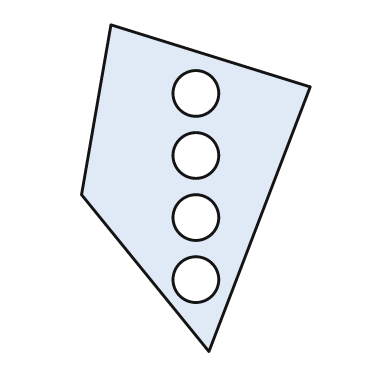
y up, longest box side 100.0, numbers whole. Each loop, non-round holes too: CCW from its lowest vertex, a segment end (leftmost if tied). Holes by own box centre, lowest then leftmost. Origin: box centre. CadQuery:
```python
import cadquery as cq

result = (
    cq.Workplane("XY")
    .moveTo(4.0, -50.0)
    .lineTo(35.0, 31.0)
    .lineTo(-26.0, 50.0)
    .lineTo(-35.0, -2.0)
    .close()
    .moveTo(0.0, -28.0)
    .circle(7.0)
    .moveTo(0.0, -9.0)
    .circle(7.0)
    .moveTo(0.0, 10.0)
    .circle(7.0)
    .moveTo(0.0, 29.0)
    .circle(7.0)
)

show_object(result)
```